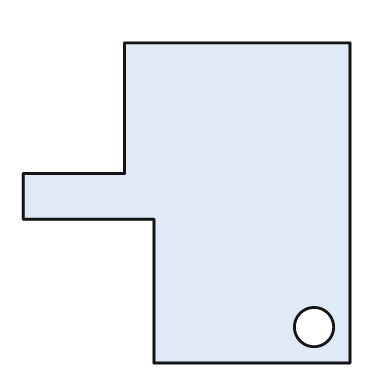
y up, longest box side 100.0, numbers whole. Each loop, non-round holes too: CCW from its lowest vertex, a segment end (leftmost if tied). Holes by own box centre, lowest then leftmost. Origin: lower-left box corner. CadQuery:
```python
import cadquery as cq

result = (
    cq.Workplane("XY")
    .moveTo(40.0, 0.0)
    .lineTo(100.0, 0.0)
    .lineTo(100.0, 98.0)
    .lineTo(31.0, 98.0)
    .lineTo(31.0, 58.0)
    .lineTo(0.0, 58.0)
    .lineTo(0.0, 44.0)
    .lineTo(40.0, 44.0)
    .close()
    .moveTo(89.0, 11.0)
    .circle(6.0)
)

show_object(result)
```